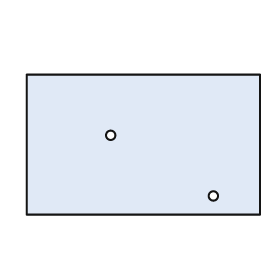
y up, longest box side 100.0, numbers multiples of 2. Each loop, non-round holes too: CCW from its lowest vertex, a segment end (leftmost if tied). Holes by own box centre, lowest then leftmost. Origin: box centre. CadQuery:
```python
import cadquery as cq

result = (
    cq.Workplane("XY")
    .moveTo(-50.0, -30.0)
    .lineTo(50.0, -30.0)
    .lineTo(50.0, 30.0)
    .lineTo(-50.0, 30.0)
    .close()
    .moveTo(30.0, -22.0)
    .circle(2.0)
    .moveTo(-14.0, 4.0)
    .circle(2.0)
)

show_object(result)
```